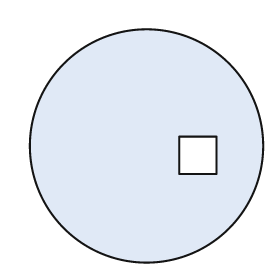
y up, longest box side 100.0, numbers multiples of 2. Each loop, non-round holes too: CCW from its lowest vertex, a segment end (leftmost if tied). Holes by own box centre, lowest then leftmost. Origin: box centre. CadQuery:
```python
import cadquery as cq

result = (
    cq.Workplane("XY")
    .moveTo(0.0, 0.0)
    .circle(50.0)
    .moveTo(14.0, -12.0)
    .lineTo(30.0, -12.0)
    .lineTo(30.0, 4.0)
    .lineTo(14.0, 4.0)
    .close()
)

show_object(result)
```